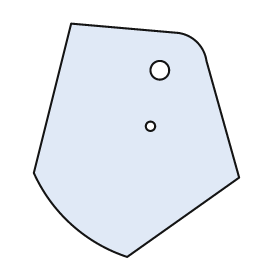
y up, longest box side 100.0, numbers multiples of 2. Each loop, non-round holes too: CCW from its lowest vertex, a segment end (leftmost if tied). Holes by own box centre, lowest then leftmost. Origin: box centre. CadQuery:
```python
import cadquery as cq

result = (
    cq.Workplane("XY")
    .moveTo(-4.0, -50.0)
    .lineTo(44.0, -16.0)
    .lineTo(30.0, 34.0)
    .threePointArc((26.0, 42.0), (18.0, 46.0))
    .lineTo(-28.0, 50.0)
    .lineTo(-44.0, -14.0)
    .threePointArc((-28.0, -36.0), (-4.0, -50.0))
    .close()
    .moveTo(6.0, 6.0)
    .circle(2.0)
    .moveTo(10.0, 30.0)
    .circle(4.0)
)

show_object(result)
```